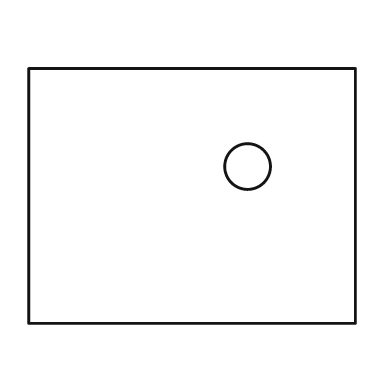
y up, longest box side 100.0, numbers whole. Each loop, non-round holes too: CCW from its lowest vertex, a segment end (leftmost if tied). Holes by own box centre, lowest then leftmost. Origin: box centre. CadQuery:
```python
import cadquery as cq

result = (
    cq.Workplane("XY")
    .moveTo(-50.0, -39.0)
    .lineTo(50.0, -39.0)
    .lineTo(50.0, 39.0)
    .lineTo(-50.0, 39.0)
    .close()
    .moveTo(17.0, 9.0)
    .circle(7.0)
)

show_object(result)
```